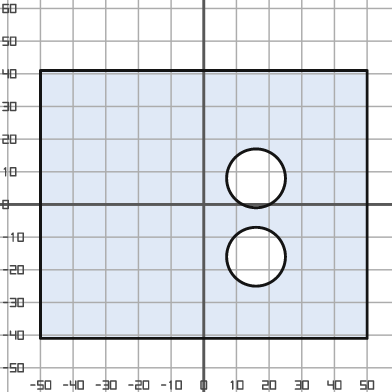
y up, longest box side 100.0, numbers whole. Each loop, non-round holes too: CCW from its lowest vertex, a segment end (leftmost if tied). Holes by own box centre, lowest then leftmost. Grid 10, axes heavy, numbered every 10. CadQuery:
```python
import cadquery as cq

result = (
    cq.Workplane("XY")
    .moveTo(-50.0, -41.0)
    .lineTo(50.0, -41.0)
    .lineTo(50.0, 41.0)
    .lineTo(-50.0, 41.0)
    .close()
    .moveTo(16.0, -16.0)
    .circle(9.0)
    .moveTo(16.0, 8.0)
    .circle(9.0)
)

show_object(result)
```